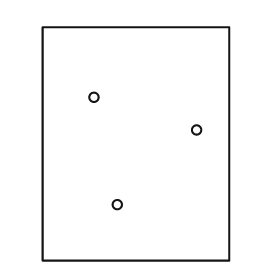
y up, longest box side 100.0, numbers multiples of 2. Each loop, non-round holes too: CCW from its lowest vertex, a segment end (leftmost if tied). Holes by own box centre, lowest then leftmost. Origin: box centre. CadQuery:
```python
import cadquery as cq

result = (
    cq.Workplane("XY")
    .moveTo(-40.0, -50.0)
    .lineTo(40.0, -50.0)
    .lineTo(40.0, 50.0)
    .lineTo(-40.0, 50.0)
    .close()
    .moveTo(-8.0, -26.0)
    .circle(2.0)
    .moveTo(26.0, 6.0)
    .circle(2.0)
    .moveTo(-18.0, 20.0)
    .circle(2.0)
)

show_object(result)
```